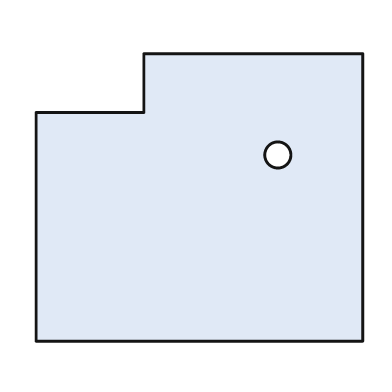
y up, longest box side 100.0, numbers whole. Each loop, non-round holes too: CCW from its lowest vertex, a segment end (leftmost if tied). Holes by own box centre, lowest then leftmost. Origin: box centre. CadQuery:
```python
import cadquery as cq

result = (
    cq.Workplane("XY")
    .moveTo(-50.0, -44.0)
    .lineTo(50.0, -44.0)
    .lineTo(50.0, 44.0)
    .lineTo(-17.0, 44.0)
    .lineTo(-17.0, 26.0)
    .lineTo(-50.0, 26.0)
    .close()
    .moveTo(24.0, 13.0)
    .circle(4.0)
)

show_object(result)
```